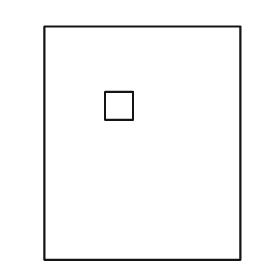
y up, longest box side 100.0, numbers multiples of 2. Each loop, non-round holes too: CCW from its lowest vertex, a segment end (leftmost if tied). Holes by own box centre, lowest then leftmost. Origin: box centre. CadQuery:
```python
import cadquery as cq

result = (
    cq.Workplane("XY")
    .moveTo(-42.0, -50.0)
    .lineTo(42.0, -50.0)
    .lineTo(42.0, 50.0)
    .lineTo(-42.0, 50.0)
    .close()
    .moveTo(-16.0, 10.0)
    .lineTo(-4.0, 10.0)
    .lineTo(-4.0, 22.0)
    .lineTo(-16.0, 22.0)
    .close()
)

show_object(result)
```